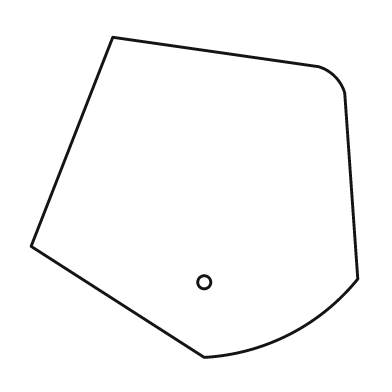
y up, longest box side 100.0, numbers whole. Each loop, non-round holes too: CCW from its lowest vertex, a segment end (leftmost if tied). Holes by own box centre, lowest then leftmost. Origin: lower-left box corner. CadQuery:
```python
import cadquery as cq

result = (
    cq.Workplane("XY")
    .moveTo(53.0, 0.0)
    .threePointArc((79.0, 7.0), (100.0, 24.0))
    .lineTo(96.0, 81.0)
    .threePointArc((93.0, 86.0), (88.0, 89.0))
    .lineTo(25.0, 98.0)
    .lineTo(0.0, 34.0)
    .close()
    .moveTo(53.0, 23.0)
    .circle(2.0)
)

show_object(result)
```